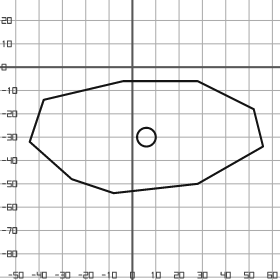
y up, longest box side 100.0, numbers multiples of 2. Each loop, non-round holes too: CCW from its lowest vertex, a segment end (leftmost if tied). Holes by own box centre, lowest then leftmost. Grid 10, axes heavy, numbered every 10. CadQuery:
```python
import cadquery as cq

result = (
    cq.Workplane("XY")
    .moveTo(-8.0, -54.0)
    .lineTo(28.0, -50.0)
    .lineTo(56.0, -34.0)
    .lineTo(52.0, -18.0)
    .lineTo(28.0, -6.0)
    .lineTo(-4.0, -6.0)
    .lineTo(-38.0, -14.0)
    .lineTo(-44.0, -32.0)
    .lineTo(-26.0, -48.0)
    .close()
    .moveTo(6.0, -30.0)
    .circle(4.0)
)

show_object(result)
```